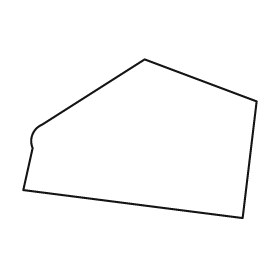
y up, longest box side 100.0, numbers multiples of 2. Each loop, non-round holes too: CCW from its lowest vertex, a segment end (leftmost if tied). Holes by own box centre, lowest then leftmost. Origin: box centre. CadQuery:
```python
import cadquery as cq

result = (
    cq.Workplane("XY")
    .moveTo(44.0, -34.0)
    .lineTo(50.0, 16.0)
    .lineTo(2.0, 34.0)
    .lineTo(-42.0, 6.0)
    .threePointArc((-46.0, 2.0), (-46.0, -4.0))
    .lineTo(-50.0, -22.0)
    .close()
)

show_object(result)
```